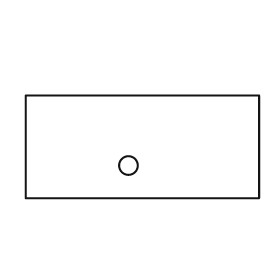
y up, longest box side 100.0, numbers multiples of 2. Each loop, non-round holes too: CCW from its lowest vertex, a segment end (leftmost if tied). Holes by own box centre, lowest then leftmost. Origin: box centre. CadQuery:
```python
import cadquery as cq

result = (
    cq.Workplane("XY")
    .moveTo(-50.0, -22.0)
    .lineTo(50.0, -22.0)
    .lineTo(50.0, 22.0)
    .lineTo(-50.0, 22.0)
    .close()
    .moveTo(-6.0, -8.0)
    .circle(4.0)
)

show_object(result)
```